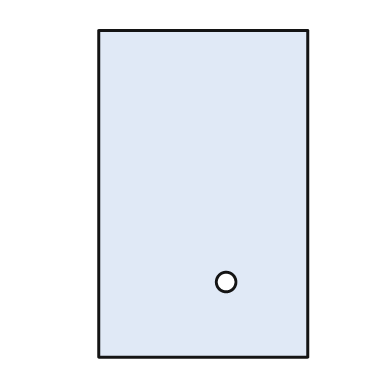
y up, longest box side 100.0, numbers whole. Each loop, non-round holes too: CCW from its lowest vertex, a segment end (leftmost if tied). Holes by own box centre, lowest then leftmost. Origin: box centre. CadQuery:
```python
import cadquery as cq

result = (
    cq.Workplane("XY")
    .moveTo(-32.0, -50.0)
    .lineTo(32.0, -50.0)
    .lineTo(32.0, 50.0)
    .lineTo(-32.0, 50.0)
    .close()
    .moveTo(7.0, -27.0)
    .circle(3.0)
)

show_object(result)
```